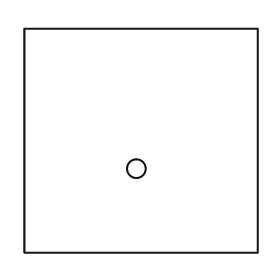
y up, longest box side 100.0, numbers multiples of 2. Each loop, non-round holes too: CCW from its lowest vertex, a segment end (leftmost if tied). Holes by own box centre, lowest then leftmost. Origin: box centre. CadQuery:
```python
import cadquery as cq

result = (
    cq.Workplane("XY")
    .moveTo(-50.0, -48.0)
    .lineTo(50.0, -48.0)
    .lineTo(50.0, 48.0)
    .lineTo(-50.0, 48.0)
    .close()
    .moveTo(-2.0, -12.0)
    .circle(4.0)
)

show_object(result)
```